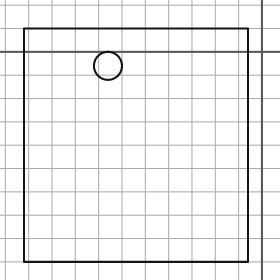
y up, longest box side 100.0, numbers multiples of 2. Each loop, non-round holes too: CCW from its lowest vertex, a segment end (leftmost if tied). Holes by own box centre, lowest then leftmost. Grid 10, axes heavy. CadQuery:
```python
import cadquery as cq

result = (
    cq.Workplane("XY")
    .moveTo(-102.0, -90.0)
    .lineTo(-6.0, -90.0)
    .lineTo(-6.0, 10.0)
    .lineTo(-102.0, 10.0)
    .close()
    .moveTo(-66.0, -6.0)
    .circle(6.0)
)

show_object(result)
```